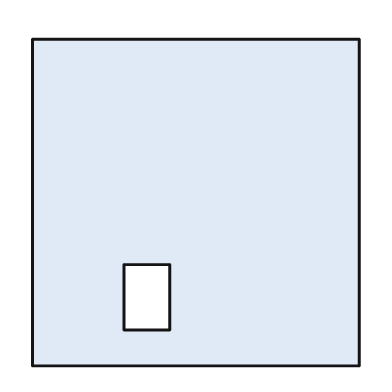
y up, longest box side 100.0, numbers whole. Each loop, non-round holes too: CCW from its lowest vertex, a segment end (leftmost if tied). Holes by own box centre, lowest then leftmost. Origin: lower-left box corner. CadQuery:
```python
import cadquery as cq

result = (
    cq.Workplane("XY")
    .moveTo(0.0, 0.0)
    .lineTo(100.0, 0.0)
    .lineTo(100.0, 100.0)
    .lineTo(0.0, 100.0)
    .close()
    .moveTo(28.0, 11.0)
    .lineTo(42.0, 11.0)
    .lineTo(42.0, 31.0)
    .lineTo(28.0, 31.0)
    .close()
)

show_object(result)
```